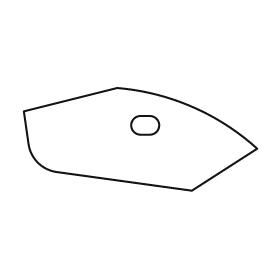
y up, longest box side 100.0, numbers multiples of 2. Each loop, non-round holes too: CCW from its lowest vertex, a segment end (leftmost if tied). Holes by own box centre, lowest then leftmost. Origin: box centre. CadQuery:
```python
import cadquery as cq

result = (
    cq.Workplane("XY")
    .moveTo(22.0, -22.0)
    .lineTo(50.0, -4.0)
    .threePointArc((22.0, 14.0), (-10.0, 22.0))
    .lineTo(-50.0, 12.0)
    .lineTo(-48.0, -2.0)
    .threePointArc((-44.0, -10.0), (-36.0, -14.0))
    .close()
    .moveTo(0.0, 2.0)
    .lineTo(4.0, 2.0)
    .threePointArc((8.0, 6.0), (4.0, 10.0))
    .lineTo(0.0, 10.0)
    .threePointArc((-4.0, 6.0), (0.0, 2.0))
    .close()
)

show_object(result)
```